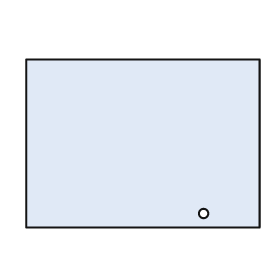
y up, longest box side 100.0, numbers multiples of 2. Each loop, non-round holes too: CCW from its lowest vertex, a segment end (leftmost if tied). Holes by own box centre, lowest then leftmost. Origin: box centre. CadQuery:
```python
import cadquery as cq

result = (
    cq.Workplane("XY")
    .moveTo(-50.0, -36.0)
    .lineTo(50.0, -36.0)
    .lineTo(50.0, 36.0)
    .lineTo(-50.0, 36.0)
    .close()
    .moveTo(26.0, -30.0)
    .circle(2.0)
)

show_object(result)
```